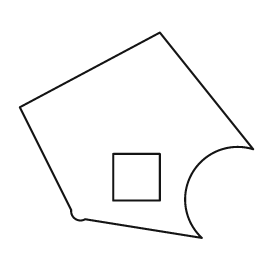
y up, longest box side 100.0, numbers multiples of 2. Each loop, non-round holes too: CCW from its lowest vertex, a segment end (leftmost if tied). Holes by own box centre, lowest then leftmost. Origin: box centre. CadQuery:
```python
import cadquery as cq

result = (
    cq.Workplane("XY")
    .moveTo(28.0, -44.0)
    .threePointArc((24.0, -16.0), (50.0, -6.0))
    .lineTo(10.0, 44.0)
    .lineTo(-50.0, 12.0)
    .lineTo(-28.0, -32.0)
    .threePointArc((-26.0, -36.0), (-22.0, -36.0))
    .close()
    .moveTo(-10.0, -28.0)
    .lineTo(10.0, -28.0)
    .lineTo(10.0, -8.0)
    .lineTo(-10.0, -8.0)
    .close()
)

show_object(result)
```